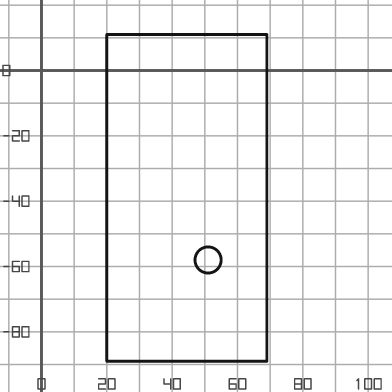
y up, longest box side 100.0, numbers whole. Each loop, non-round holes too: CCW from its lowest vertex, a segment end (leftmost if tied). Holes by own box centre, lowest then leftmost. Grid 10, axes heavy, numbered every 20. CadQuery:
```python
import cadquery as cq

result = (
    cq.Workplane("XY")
    .moveTo(20.0, -89.0)
    .lineTo(69.0, -89.0)
    .lineTo(69.0, 11.0)
    .lineTo(20.0, 11.0)
    .close()
    .moveTo(51.0, -58.0)
    .circle(4.0)
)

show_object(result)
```